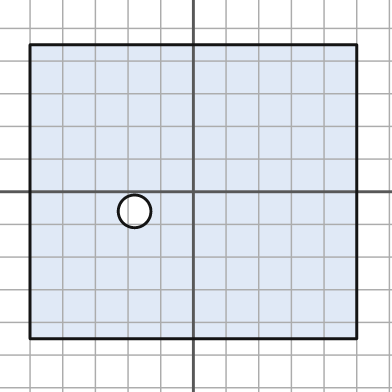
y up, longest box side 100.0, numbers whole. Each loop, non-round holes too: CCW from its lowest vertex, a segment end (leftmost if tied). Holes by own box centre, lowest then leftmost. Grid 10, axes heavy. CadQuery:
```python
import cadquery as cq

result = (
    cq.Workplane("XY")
    .moveTo(-50.0, -45.0)
    .lineTo(50.0, -45.0)
    .lineTo(50.0, 45.0)
    .lineTo(-50.0, 45.0)
    .close()
    .moveTo(-18.0, -6.0)
    .circle(5.0)
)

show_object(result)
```